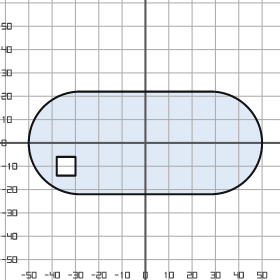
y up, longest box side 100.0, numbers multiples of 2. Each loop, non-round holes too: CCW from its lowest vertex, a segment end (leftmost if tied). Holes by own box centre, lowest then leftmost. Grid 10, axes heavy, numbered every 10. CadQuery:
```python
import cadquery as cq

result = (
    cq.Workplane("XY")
    .moveTo(-28.0, -22.0)
    .lineTo(28.0, -22.0)
    .threePointArc((50.0, 0.0), (28.0, 22.0))
    .lineTo(-28.0, 22.0)
    .threePointArc((-50.0, 0.0), (-28.0, -22.0))
    .close()
    .moveTo(-38.0, -14.0)
    .lineTo(-30.0, -14.0)
    .lineTo(-30.0, -6.0)
    .lineTo(-38.0, -6.0)
    .close()
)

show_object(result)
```